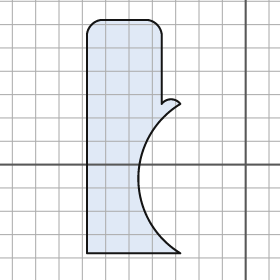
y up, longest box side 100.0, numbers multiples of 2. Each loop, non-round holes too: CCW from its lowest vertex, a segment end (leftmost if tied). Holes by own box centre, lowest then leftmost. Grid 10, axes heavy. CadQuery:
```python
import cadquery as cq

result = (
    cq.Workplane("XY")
    .moveTo(-68.0, -38.0)
    .lineTo(-28.0, -38.0)
    .threePointArc((-46.0, -6.0), (-28.0, 26.0))
    .threePointArc((-32.0, 28.0), (-36.0, 26.0))
    .lineTo(-36.0, 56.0)
    .threePointArc((-38.0, 60.0), (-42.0, 62.0))
    .lineTo(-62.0, 62.0)
    .threePointArc((-66.0, 60.0), (-68.0, 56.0))
    .close()
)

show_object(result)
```